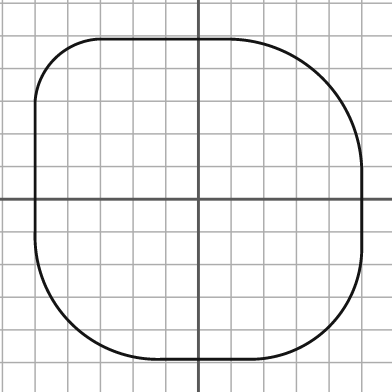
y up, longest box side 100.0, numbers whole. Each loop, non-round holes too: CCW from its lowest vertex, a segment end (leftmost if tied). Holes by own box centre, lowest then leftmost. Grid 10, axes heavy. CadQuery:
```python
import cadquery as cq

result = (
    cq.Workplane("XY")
    .moveTo(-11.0, -49.0)
    .lineTo(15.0, -49.0)
    .threePointArc((40.0, -39.0), (50.0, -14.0))
    .lineTo(50.0, 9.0)
    .threePointArc((38.0, 37.0), (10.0, 49.0))
    .lineTo(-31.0, 49.0)
    .threePointArc((-44.0, 43.0), (-50.0, 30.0))
    .lineTo(-50.0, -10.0)
    .threePointArc((-39.0, -38.0), (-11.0, -49.0))
    .close()
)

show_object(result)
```